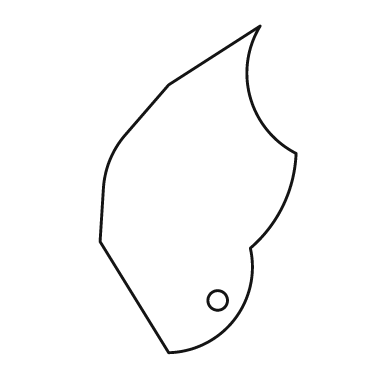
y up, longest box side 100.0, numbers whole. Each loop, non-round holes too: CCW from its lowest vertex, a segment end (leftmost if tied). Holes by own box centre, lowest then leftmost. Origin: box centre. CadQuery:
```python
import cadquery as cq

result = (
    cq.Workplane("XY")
    .moveTo(-9.0, -50.0)
    .threePointArc((11.0, -40.0), (16.0, -18.0))
    .threePointArc((26.0, -5.0), (30.0, 11.0))
    .threePointArc((16.0, 28.0), (19.0, 50.0))
    .lineTo(-9.0, 32.0)
    .lineTo(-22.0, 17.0)
    .threePointArc((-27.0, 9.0), (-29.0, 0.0))
    .lineTo(-30.0, -16.0)
    .close()
    .moveTo(6.0, -34.0)
    .circle(3.0)
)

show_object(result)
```